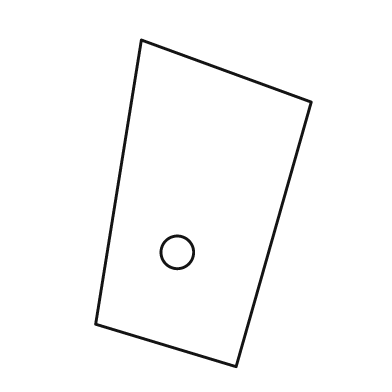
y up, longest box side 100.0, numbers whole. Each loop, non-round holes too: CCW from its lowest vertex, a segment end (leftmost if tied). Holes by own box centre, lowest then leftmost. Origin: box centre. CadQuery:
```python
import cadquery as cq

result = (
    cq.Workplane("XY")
    .moveTo(10.0, -50.0)
    .lineTo(33.0, 31.0)
    .lineTo(-19.0, 50.0)
    .lineTo(-33.0, -37.0)
    .close()
    .moveTo(-8.0, -15.0)
    .circle(5.0)
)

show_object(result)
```